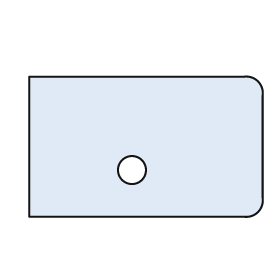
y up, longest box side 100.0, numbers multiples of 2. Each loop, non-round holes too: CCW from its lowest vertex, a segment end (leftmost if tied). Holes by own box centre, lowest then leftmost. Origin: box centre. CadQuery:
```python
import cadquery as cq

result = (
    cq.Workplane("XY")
    .moveTo(-50.0, -30.0)
    .lineTo(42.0, -30.0)
    .threePointArc((48.0, -28.0), (50.0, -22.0))
    .lineTo(50.0, 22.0)
    .threePointArc((48.0, 28.0), (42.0, 30.0))
    .lineTo(-50.0, 30.0)
    .close()
    .moveTo(-6.0, -10.0)
    .circle(6.0)
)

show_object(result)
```